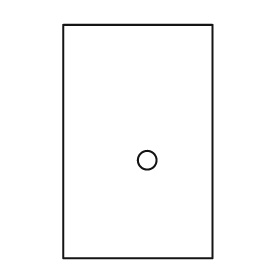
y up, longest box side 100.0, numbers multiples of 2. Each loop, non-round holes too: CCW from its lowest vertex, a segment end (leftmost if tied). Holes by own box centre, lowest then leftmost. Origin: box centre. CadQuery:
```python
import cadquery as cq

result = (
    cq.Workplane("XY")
    .moveTo(-32.0, -50.0)
    .lineTo(32.0, -50.0)
    .lineTo(32.0, 50.0)
    .lineTo(-32.0, 50.0)
    .close()
    .moveTo(4.0, -8.0)
    .circle(4.0)
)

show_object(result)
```